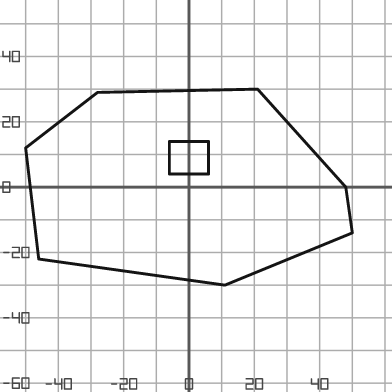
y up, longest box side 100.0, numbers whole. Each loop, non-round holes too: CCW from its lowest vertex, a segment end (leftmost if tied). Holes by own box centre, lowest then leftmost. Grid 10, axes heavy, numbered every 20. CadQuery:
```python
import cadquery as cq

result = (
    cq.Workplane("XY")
    .moveTo(11.0, -30.0)
    .lineTo(50.0, -14.0)
    .lineTo(48.0, 0.0)
    .lineTo(21.0, 30.0)
    .lineTo(-28.0, 29.0)
    .lineTo(-50.0, 12.0)
    .lineTo(-46.0, -22.0)
    .close()
    .moveTo(-6.0, 4.0)
    .lineTo(6.0, 4.0)
    .lineTo(6.0, 14.0)
    .lineTo(-6.0, 14.0)
    .close()
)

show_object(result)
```